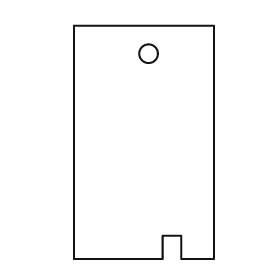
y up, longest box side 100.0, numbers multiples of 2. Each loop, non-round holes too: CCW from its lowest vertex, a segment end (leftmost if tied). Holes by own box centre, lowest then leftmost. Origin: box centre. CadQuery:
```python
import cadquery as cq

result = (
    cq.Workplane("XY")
    .moveTo(-30.0, -50.0)
    .lineTo(8.0, -50.0)
    .lineTo(8.0, -40.0)
    .lineTo(16.0, -40.0)
    .lineTo(16.0, -50.0)
    .lineTo(30.0, -50.0)
    .lineTo(30.0, 50.0)
    .lineTo(-30.0, 50.0)
    .close()
    .moveTo(2.0, 38.0)
    .circle(4.0)
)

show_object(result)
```